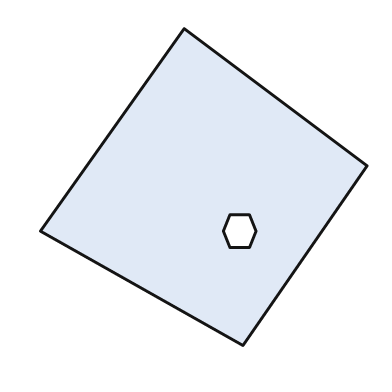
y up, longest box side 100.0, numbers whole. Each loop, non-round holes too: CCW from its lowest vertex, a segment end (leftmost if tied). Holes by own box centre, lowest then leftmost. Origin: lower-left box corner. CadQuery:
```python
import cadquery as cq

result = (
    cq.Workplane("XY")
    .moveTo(62.0, 0.0)
    .lineTo(100.0, 55.0)
    .lineTo(44.0, 97.0)
    .lineTo(0.0, 35.0)
    .close()
    .moveTo(58.0, 30.0)
    .lineTo(64.0, 30.0)
    .lineTo(66.0, 35.0)
    .lineTo(64.0, 40.0)
    .lineTo(58.0, 40.0)
    .lineTo(56.0, 35.0)
    .close()
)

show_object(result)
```